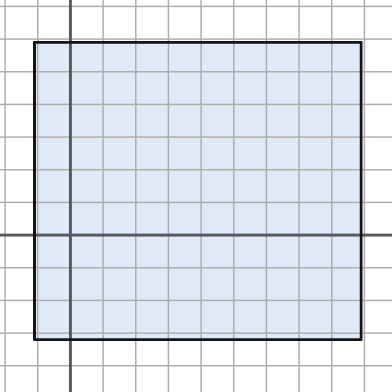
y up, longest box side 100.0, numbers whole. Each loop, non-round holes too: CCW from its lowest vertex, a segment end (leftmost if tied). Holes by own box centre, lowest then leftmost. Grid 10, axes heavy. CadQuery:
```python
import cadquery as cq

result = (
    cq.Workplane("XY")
    .moveTo(-11.0, -32.0)
    .lineTo(89.0, -32.0)
    .lineTo(89.0, 59.0)
    .lineTo(-11.0, 59.0)
    .close()
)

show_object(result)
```